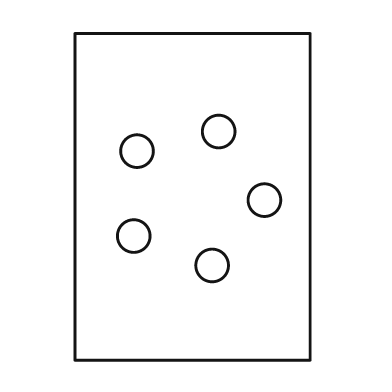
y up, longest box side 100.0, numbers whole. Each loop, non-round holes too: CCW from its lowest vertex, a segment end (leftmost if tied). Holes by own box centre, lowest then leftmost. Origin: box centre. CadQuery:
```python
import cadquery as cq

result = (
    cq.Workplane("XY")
    .moveTo(-36.0, -50.0)
    .lineTo(36.0, -50.0)
    .lineTo(36.0, 50.0)
    .lineTo(-36.0, 50.0)
    .close()
    .moveTo(6.0, -21.0)
    .circle(5.0)
    .moveTo(-18.0, -12.0)
    .circle(5.0)
    .moveTo(22.0, -1.0)
    .circle(5.0)
    .moveTo(-17.0, 14.0)
    .circle(5.0)
    .moveTo(8.0, 20.0)
    .circle(5.0)
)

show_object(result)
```